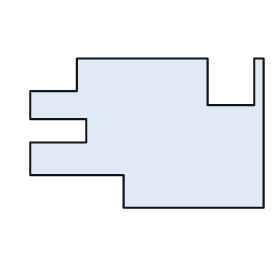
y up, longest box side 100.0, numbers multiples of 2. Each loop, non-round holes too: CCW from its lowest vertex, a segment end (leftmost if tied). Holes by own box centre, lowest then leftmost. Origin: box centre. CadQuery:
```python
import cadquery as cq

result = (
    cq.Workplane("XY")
    .moveTo(-10.0, -32.0)
    .lineTo(50.0, -32.0)
    .lineTo(50.0, 32.0)
    .lineTo(46.0, 32.0)
    .lineTo(46.0, 12.0)
    .lineTo(26.0, 12.0)
    .lineTo(26.0, 32.0)
    .lineTo(-30.0, 32.0)
    .lineTo(-30.0, 18.0)
    .lineTo(-50.0, 18.0)
    .lineTo(-50.0, 6.0)
    .lineTo(-26.0, 6.0)
    .lineTo(-26.0, -4.0)
    .lineTo(-50.0, -4.0)
    .lineTo(-50.0, -18.0)
    .lineTo(-10.0, -18.0)
    .close()
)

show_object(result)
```